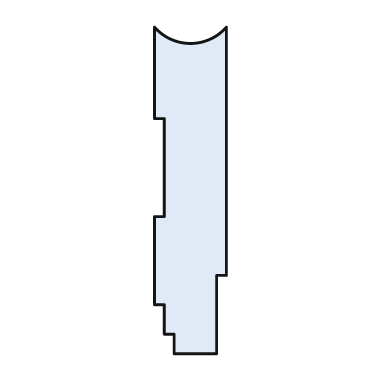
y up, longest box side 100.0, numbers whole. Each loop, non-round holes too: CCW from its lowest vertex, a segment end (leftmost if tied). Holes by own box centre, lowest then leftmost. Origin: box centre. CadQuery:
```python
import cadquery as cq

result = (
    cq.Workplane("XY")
    .moveTo(-5.0, -50.0)
    .lineTo(8.0, -50.0)
    .lineTo(8.0, -26.0)
    .lineTo(11.0, -26.0)
    .lineTo(11.0, 50.0)
    .threePointArc((0.0, 45.0), (-11.0, 50.0))
    .lineTo(-11.0, 22.0)
    .lineTo(-8.0, 22.0)
    .lineTo(-8.0, -8.0)
    .lineTo(-11.0, -8.0)
    .lineTo(-11.0, -35.0)
    .lineTo(-8.0, -35.0)
    .lineTo(-8.0, -44.0)
    .lineTo(-5.0, -44.0)
    .close()
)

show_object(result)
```